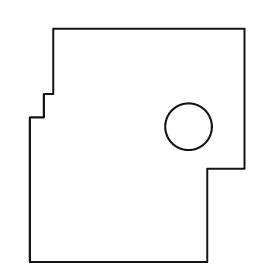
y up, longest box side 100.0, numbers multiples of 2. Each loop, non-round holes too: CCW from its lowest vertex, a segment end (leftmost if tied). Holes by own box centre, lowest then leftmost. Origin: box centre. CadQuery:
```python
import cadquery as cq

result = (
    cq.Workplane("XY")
    .moveTo(-46.0, -50.0)
    .lineTo(30.0, -50.0)
    .lineTo(30.0, -10.0)
    .lineTo(46.0, -10.0)
    .lineTo(46.0, 50.0)
    .lineTo(-36.0, 50.0)
    .lineTo(-36.0, 22.0)
    .lineTo(-40.0, 22.0)
    .lineTo(-40.0, 12.0)
    .lineTo(-46.0, 12.0)
    .close()
    .moveTo(22.0, 8.0)
    .circle(10.0)
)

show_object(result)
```